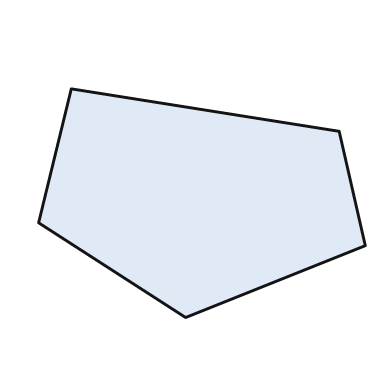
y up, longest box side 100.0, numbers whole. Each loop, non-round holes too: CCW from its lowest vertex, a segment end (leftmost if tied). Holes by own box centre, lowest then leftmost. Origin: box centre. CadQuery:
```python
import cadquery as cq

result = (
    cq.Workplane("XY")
    .moveTo(-5.0, -35.0)
    .lineTo(50.0, -13.0)
    .lineTo(42.0, 22.0)
    .lineTo(-40.0, 35.0)
    .lineTo(-50.0, -6.0)
    .close()
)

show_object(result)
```